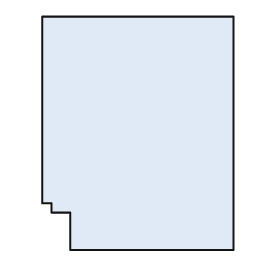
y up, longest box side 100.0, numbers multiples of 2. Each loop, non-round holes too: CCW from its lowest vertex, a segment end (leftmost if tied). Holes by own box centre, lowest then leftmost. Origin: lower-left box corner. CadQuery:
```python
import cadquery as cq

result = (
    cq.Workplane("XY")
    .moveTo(12.0, 0.0)
    .lineTo(82.0, 0.0)
    .lineTo(82.0, 100.0)
    .lineTo(0.0, 100.0)
    .lineTo(0.0, 20.0)
    .lineTo(4.0, 20.0)
    .lineTo(4.0, 16.0)
    .lineTo(12.0, 16.0)
    .close()
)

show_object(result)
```